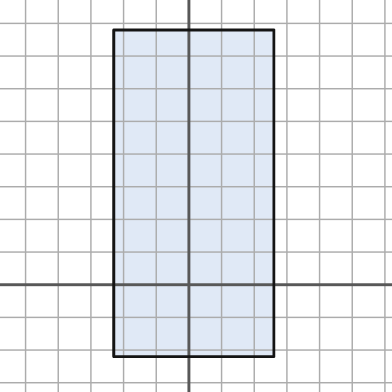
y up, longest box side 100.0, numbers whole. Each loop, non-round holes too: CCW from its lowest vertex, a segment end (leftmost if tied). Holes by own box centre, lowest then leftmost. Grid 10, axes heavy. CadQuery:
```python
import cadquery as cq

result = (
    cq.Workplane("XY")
    .moveTo(-23.0, -22.0)
    .lineTo(26.0, -22.0)
    .lineTo(26.0, 78.0)
    .lineTo(-23.0, 78.0)
    .close()
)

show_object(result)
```